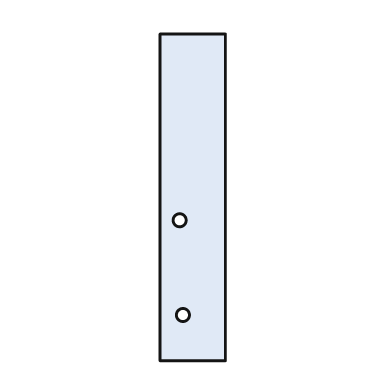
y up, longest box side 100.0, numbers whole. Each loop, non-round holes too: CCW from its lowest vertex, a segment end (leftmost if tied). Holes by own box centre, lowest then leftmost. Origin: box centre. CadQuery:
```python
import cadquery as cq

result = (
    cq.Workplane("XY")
    .moveTo(-10.0, -50.0)
    .lineTo(10.0, -50.0)
    .lineTo(10.0, 50.0)
    .lineTo(-10.0, 50.0)
    .close()
    .moveTo(-3.0, -36.0)
    .circle(2.0)
    .moveTo(-4.0, -7.0)
    .circle(2.0)
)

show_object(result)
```